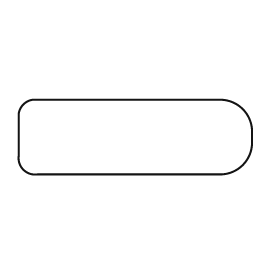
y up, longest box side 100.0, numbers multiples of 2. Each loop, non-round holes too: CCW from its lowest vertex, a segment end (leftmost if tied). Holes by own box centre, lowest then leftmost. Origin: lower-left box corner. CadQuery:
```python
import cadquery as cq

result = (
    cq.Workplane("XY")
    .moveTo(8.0, 0.0)
    .lineTo(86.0, 0.0)
    .threePointArc((96.0, 4.0), (100.0, 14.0))
    .lineTo(100.0, 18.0)
    .threePointArc((96.0, 28.0), (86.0, 32.0))
    .lineTo(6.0, 32.0)
    .threePointArc((2.0, 30.0), (0.0, 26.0))
    .lineTo(0.0, 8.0)
    .threePointArc((2.0, 2.0), (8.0, 0.0))
    .close()
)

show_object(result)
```